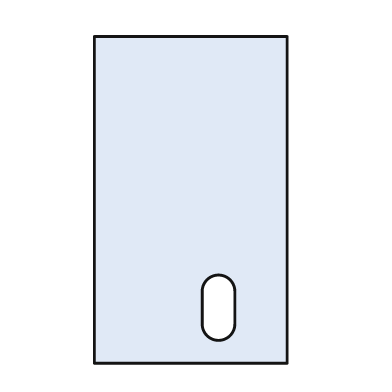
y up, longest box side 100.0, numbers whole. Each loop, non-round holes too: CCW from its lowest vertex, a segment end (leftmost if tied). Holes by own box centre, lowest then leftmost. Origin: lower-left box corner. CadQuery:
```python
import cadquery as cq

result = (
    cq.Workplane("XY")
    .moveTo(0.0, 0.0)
    .lineTo(59.0, 0.0)
    .lineTo(59.0, 100.0)
    .lineTo(0.0, 100.0)
    .close()
    .moveTo(33.0, 12.0)
    .threePointArc((38.0, 7.0), (43.0, 12.0))
    .lineTo(43.0, 22.0)
    .threePointArc((38.0, 27.0), (33.0, 22.0))
    .close()
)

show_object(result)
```